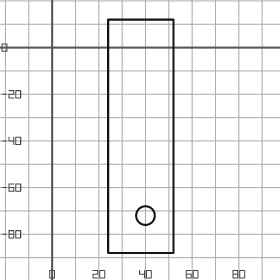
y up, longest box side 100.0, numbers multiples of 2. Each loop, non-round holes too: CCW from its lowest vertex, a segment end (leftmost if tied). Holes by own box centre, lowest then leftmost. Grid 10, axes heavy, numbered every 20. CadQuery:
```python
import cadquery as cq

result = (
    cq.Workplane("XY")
    .moveTo(24.0, -88.0)
    .lineTo(52.0, -88.0)
    .lineTo(52.0, 12.0)
    .lineTo(24.0, 12.0)
    .close()
    .moveTo(40.0, -72.0)
    .circle(4.0)
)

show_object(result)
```